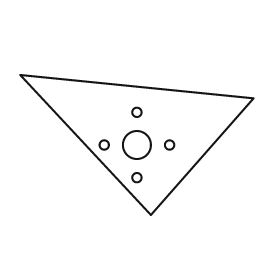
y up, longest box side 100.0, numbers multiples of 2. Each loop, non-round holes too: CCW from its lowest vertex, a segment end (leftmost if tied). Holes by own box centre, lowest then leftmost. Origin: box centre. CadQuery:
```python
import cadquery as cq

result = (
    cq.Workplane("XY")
    .moveTo(6.0, -30.0)
    .lineTo(50.0, 20.0)
    .lineTo(-50.0, 30.0)
    .close()
    .moveTo(0.0, -14.0)
    .circle(2.0)
    .moveTo(-14.0, 0.0)
    .circle(2.0)
    .moveTo(0.0, 0.0)
    .circle(6.0)
    .moveTo(14.0, 0.0)
    .circle(2.0)
    .moveTo(0.0, 14.0)
    .circle(2.0)
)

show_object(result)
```